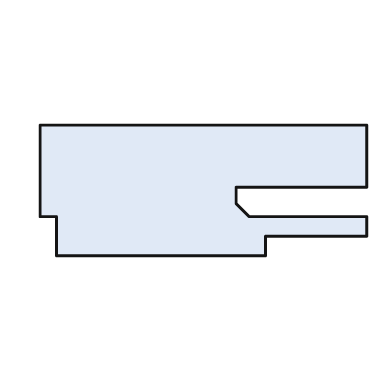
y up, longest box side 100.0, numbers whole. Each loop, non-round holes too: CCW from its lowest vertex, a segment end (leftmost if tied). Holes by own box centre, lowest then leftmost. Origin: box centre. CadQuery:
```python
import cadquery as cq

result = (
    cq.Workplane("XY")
    .moveTo(-45.0, -20.0)
    .lineTo(19.0, -20.0)
    .lineTo(19.0, -14.0)
    .lineTo(50.0, -14.0)
    .lineTo(50.0, -8.0)
    .lineTo(14.0, -8.0)
    .lineTo(10.0, -4.0)
    .lineTo(10.0, 1.0)
    .lineTo(50.0, 1.0)
    .lineTo(50.0, 20.0)
    .lineTo(-50.0, 20.0)
    .lineTo(-50.0, -8.0)
    .lineTo(-45.0, -8.0)
    .close()
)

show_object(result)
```